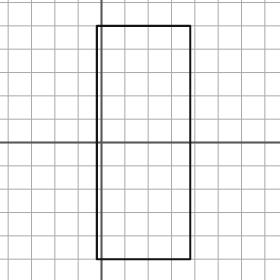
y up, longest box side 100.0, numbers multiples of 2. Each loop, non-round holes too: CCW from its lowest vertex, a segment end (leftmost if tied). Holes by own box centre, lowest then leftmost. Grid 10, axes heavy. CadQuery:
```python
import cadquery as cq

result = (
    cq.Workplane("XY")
    .moveTo(-2.0, -50.0)
    .lineTo(38.0, -50.0)
    .lineTo(38.0, 50.0)
    .lineTo(-2.0, 50.0)
    .close()
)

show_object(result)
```